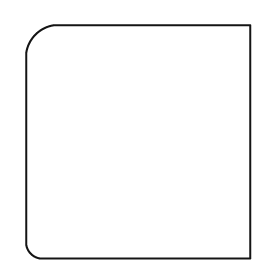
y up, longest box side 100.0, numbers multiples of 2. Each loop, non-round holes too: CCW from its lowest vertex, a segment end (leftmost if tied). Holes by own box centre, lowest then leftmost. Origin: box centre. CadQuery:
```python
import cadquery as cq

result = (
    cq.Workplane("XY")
    .moveTo(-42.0, -50.0)
    .lineTo(48.0, -50.0)
    .lineTo(48.0, 50.0)
    .lineTo(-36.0, 50.0)
    .threePointArc((-44.0, 46.0), (-48.0, 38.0))
    .lineTo(-48.0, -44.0)
    .threePointArc((-46.0, -48.0), (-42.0, -50.0))
    .close()
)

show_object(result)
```